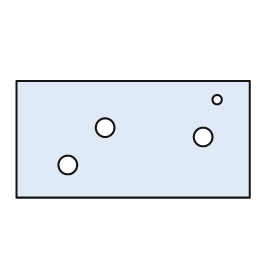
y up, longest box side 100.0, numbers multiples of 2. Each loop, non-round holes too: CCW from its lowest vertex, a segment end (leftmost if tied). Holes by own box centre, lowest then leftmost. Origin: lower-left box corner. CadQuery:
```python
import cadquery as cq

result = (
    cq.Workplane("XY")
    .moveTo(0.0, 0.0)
    .lineTo(100.0, 0.0)
    .lineTo(100.0, 50.0)
    .lineTo(0.0, 50.0)
    .close()
    .moveTo(22.0, 14.0)
    .circle(4.0)
    .moveTo(80.0, 26.0)
    .circle(4.0)
    .moveTo(38.0, 30.0)
    .circle(4.0)
    .moveTo(86.0, 42.0)
    .circle(2.0)
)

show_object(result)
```